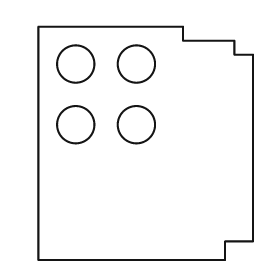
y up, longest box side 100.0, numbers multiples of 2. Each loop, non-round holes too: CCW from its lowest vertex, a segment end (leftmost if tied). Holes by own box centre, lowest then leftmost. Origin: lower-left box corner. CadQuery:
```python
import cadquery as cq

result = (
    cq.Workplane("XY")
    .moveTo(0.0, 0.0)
    .lineTo(80.0, 0.0)
    .lineTo(80.0, 8.0)
    .lineTo(92.0, 8.0)
    .lineTo(92.0, 88.0)
    .lineTo(84.0, 88.0)
    .lineTo(84.0, 94.0)
    .lineTo(62.0, 94.0)
    .lineTo(62.0, 100.0)
    .lineTo(0.0, 100.0)
    .close()
    .moveTo(16.0, 58.0)
    .circle(8.0)
    .moveTo(42.0, 58.0)
    .circle(8.0)
    .moveTo(16.0, 84.0)
    .circle(8.0)
    .moveTo(42.0, 84.0)
    .circle(8.0)
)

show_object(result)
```